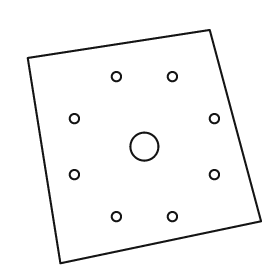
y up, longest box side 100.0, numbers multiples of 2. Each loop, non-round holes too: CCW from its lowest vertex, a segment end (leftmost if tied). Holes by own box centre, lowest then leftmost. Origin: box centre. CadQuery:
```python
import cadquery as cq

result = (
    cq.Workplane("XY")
    .moveTo(-36.0, -50.0)
    .lineTo(50.0, -32.0)
    .lineTo(28.0, 50.0)
    .lineTo(-50.0, 38.0)
    .close()
    .moveTo(-12.0, -30.0)
    .circle(2.0)
    .moveTo(12.0, -30.0)
    .circle(2.0)
    .moveTo(-30.0, -12.0)
    .circle(2.0)
    .moveTo(30.0, -12.0)
    .circle(2.0)
    .moveTo(0.0, 0.0)
    .circle(6.0)
    .moveTo(-30.0, 12.0)
    .circle(2.0)
    .moveTo(30.0, 12.0)
    .circle(2.0)
    .moveTo(-12.0, 30.0)
    .circle(2.0)
    .moveTo(12.0, 30.0)
    .circle(2.0)
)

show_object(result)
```